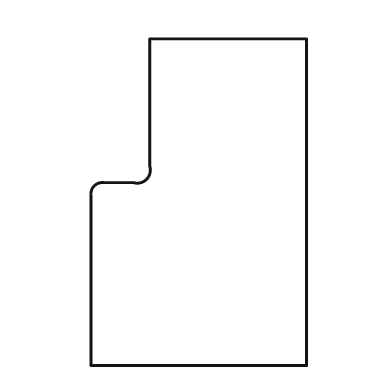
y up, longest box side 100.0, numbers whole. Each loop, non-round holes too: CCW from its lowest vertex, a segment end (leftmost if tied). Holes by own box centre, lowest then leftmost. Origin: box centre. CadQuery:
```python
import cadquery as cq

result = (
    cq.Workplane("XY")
    .moveTo(-33.0, -50.0)
    .lineTo(33.0, -50.0)
    .lineTo(33.0, 50.0)
    .lineTo(-15.0, 50.0)
    .lineTo(-15.0, 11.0)
    .threePointArc((-16.0, 7.0), (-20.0, 6.0))
    .lineTo(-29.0, 6.0)
    .threePointArc((-32.0, 5.0), (-33.0, 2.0))
    .close()
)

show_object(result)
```